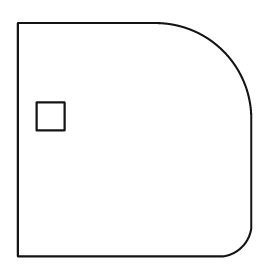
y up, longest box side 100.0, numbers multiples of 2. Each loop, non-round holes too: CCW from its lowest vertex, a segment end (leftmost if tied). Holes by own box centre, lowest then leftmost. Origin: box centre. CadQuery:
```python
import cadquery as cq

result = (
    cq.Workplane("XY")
    .moveTo(-50.0, -50.0)
    .lineTo(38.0, -50.0)
    .threePointArc((46.0, -46.0), (50.0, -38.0))
    .lineTo(50.0, 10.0)
    .threePointArc((38.0, 38.0), (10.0, 50.0))
    .lineTo(-50.0, 50.0)
    .close()
    .moveTo(-42.0, 4.0)
    .lineTo(-30.0, 4.0)
    .lineTo(-30.0, 16.0)
    .lineTo(-42.0, 16.0)
    .close()
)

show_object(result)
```